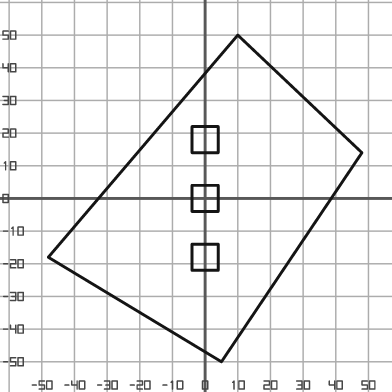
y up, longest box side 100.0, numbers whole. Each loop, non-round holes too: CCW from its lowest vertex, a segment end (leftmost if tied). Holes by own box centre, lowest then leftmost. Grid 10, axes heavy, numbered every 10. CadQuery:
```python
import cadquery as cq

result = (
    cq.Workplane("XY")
    .moveTo(5.0, -50.0)
    .lineTo(48.0, 14.0)
    .lineTo(10.0, 50.0)
    .lineTo(-48.0, -18.0)
    .close()
    .moveTo(-4.0, -22.0)
    .lineTo(4.0, -22.0)
    .lineTo(4.0, -14.0)
    .lineTo(-4.0, -14.0)
    .close()
    .moveTo(-4.0, -4.0)
    .lineTo(4.0, -4.0)
    .lineTo(4.0, 4.0)
    .lineTo(-4.0, 4.0)
    .close()
    .moveTo(-4.0, 14.0)
    .lineTo(4.0, 14.0)
    .lineTo(4.0, 22.0)
    .lineTo(-4.0, 22.0)
    .close()
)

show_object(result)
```